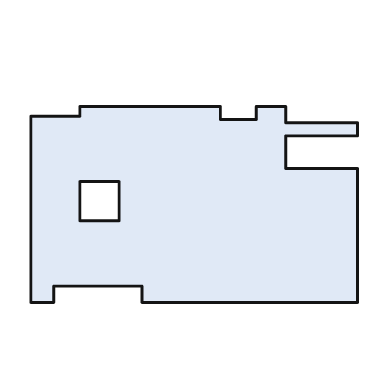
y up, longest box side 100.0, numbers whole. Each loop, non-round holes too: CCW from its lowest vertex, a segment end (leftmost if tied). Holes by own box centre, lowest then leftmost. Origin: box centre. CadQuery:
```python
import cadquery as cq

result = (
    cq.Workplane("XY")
    .moveTo(-50.0, -30.0)
    .lineTo(-43.0, -30.0)
    .lineTo(-43.0, -25.0)
    .lineTo(-16.0, -25.0)
    .lineTo(-16.0, -30.0)
    .lineTo(50.0, -30.0)
    .lineTo(50.0, 11.0)
    .lineTo(28.0, 11.0)
    .lineTo(28.0, 21.0)
    .lineTo(50.0, 21.0)
    .lineTo(50.0, 25.0)
    .lineTo(28.0, 25.0)
    .lineTo(28.0, 30.0)
    .lineTo(19.0, 30.0)
    .lineTo(19.0, 26.0)
    .lineTo(8.0, 26.0)
    .lineTo(8.0, 30.0)
    .lineTo(-35.0, 30.0)
    .lineTo(-35.0, 27.0)
    .lineTo(-50.0, 27.0)
    .close()
    .moveTo(-35.0, -5.0)
    .lineTo(-23.0, -5.0)
    .lineTo(-23.0, 7.0)
    .lineTo(-35.0, 7.0)
    .close()
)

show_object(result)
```